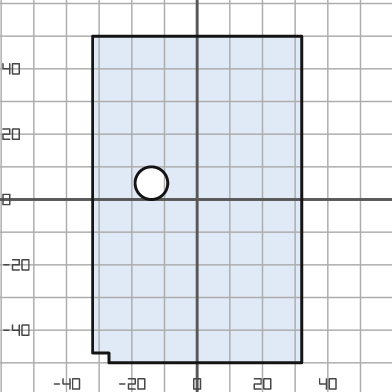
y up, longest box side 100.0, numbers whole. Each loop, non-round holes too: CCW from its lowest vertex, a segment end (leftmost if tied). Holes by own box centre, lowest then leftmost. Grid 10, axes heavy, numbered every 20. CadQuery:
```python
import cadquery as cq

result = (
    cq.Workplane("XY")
    .moveTo(-27.0, -50.0)
    .lineTo(32.0, -50.0)
    .lineTo(32.0, 50.0)
    .lineTo(-32.0, 50.0)
    .lineTo(-32.0, -47.0)
    .lineTo(-27.0, -47.0)
    .close()
    .moveTo(-14.0, 5.0)
    .circle(5.0)
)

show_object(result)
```